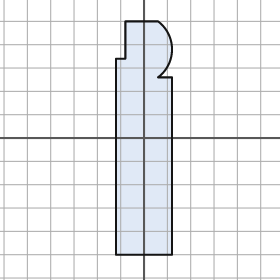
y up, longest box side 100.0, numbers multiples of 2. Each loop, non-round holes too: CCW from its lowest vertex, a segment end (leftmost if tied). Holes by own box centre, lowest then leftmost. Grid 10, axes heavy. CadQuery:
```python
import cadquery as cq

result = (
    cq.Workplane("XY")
    .moveTo(-12.0, -50.0)
    .lineTo(12.0, -50.0)
    .lineTo(12.0, 26.0)
    .lineTo(6.0, 26.0)
    .threePointArc((12.0, 38.0), (6.0, 50.0))
    .lineTo(-8.0, 50.0)
    .lineTo(-8.0, 34.0)
    .lineTo(-12.0, 34.0)
    .close()
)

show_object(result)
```